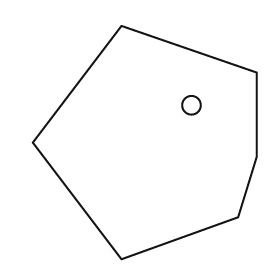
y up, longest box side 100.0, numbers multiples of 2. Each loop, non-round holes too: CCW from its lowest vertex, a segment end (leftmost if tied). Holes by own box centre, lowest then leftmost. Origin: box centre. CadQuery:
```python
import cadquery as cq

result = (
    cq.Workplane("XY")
    .moveTo(-10.0, -50.0)
    .lineTo(40.0, -32.0)
    .lineTo(48.0, -6.0)
    .lineTo(48.0, 30.0)
    .lineTo(-10.0, 50.0)
    .lineTo(-48.0, 0.0)
    .close()
    .moveTo(20.0, 16.0)
    .circle(4.0)
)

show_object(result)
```